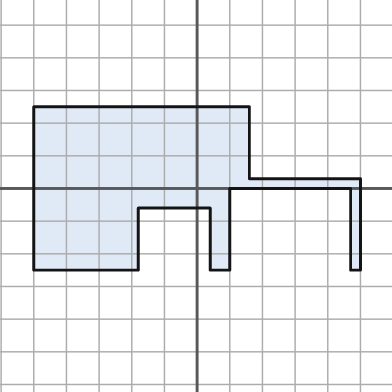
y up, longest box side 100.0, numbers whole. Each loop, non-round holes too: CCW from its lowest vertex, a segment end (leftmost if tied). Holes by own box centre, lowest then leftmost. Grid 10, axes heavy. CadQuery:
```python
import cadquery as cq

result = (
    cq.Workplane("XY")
    .moveTo(-50.0, -25.0)
    .lineTo(-18.0, -25.0)
    .lineTo(-18.0, -6.0)
    .lineTo(4.0, -6.0)
    .lineTo(4.0, -25.0)
    .lineTo(10.0, -25.0)
    .lineTo(10.0, 0.0)
    .lineTo(47.0, 0.0)
    .lineTo(47.0, -25.0)
    .lineTo(50.0, -25.0)
    .lineTo(50.0, 3.0)
    .lineTo(16.0, 3.0)
    .lineTo(16.0, 25.0)
    .lineTo(-50.0, 25.0)
    .close()
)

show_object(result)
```